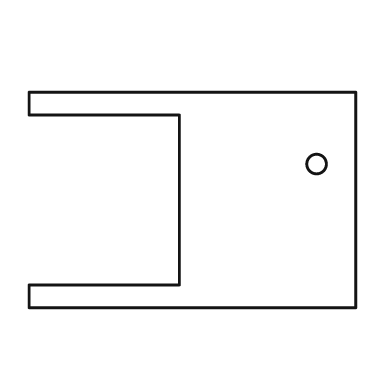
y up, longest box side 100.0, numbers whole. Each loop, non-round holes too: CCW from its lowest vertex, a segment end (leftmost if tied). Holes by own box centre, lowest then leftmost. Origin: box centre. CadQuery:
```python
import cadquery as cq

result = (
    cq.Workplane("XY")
    .moveTo(-50.0, -33.0)
    .lineTo(50.0, -33.0)
    .lineTo(50.0, 33.0)
    .lineTo(-50.0, 33.0)
    .lineTo(-50.0, 26.0)
    .lineTo(-4.0, 26.0)
    .lineTo(-4.0, -26.0)
    .lineTo(-50.0, -26.0)
    .close()
    .moveTo(38.0, 11.0)
    .circle(3.0)
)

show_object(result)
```